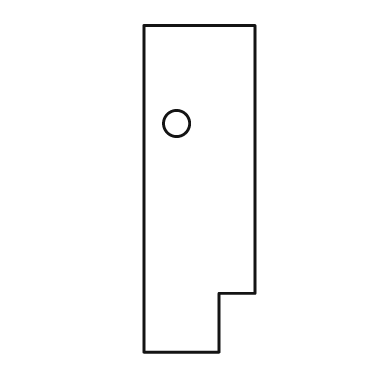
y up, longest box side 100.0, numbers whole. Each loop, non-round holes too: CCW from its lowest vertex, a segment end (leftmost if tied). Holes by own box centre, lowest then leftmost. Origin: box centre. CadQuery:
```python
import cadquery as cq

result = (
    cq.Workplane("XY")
    .moveTo(-17.0, -50.0)
    .lineTo(6.0, -50.0)
    .lineTo(6.0, -32.0)
    .lineTo(17.0, -32.0)
    .lineTo(17.0, 50.0)
    .lineTo(-17.0, 50.0)
    .close()
    .moveTo(-7.0, 20.0)
    .circle(4.0)
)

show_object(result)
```